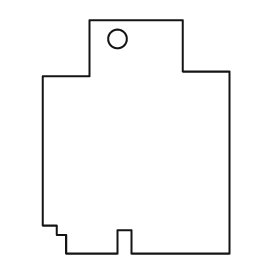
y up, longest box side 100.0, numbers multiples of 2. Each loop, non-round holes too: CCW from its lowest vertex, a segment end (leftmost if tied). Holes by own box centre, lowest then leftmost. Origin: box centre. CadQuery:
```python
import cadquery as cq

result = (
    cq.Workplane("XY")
    .moveTo(-30.0, -50.0)
    .lineTo(-8.0, -50.0)
    .lineTo(-8.0, -40.0)
    .lineTo(-2.0, -40.0)
    .lineTo(-2.0, -50.0)
    .lineTo(40.0, -50.0)
    .lineTo(40.0, 28.0)
    .lineTo(20.0, 28.0)
    .lineTo(20.0, 50.0)
    .lineTo(-20.0, 50.0)
    .lineTo(-20.0, 26.0)
    .lineTo(-40.0, 26.0)
    .lineTo(-40.0, -38.0)
    .lineTo(-34.0, -38.0)
    .lineTo(-34.0, -42.0)
    .lineTo(-30.0, -42.0)
    .close()
    .moveTo(-8.0, 42.0)
    .circle(4.0)
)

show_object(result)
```